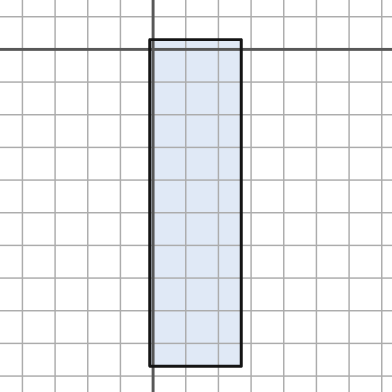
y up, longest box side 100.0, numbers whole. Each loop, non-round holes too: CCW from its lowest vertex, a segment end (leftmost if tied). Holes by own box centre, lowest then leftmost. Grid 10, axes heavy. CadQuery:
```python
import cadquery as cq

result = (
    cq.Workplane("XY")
    .moveTo(-1.0, -97.0)
    .lineTo(27.0, -97.0)
    .lineTo(27.0, 3.0)
    .lineTo(-1.0, 3.0)
    .close()
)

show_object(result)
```